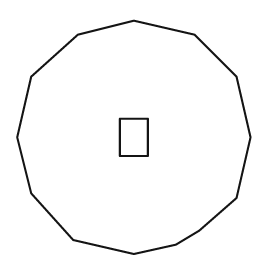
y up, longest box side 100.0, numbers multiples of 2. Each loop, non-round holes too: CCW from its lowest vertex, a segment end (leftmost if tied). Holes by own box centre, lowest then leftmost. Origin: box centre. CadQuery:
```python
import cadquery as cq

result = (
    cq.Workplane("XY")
    .moveTo(0.0, -50.0)
    .lineTo(18.0, -46.0)
    .lineTo(28.0, -40.0)
    .lineTo(44.0, -26.0)
    .lineTo(50.0, 0.0)
    .lineTo(44.0, 26.0)
    .lineTo(26.0, 44.0)
    .lineTo(0.0, 50.0)
    .lineTo(-24.0, 44.0)
    .lineTo(-44.0, 26.0)
    .lineTo(-50.0, 0.0)
    .lineTo(-44.0, -24.0)
    .lineTo(-26.0, -44.0)
    .close()
    .moveTo(-6.0, -8.0)
    .lineTo(6.0, -8.0)
    .lineTo(6.0, 8.0)
    .lineTo(-6.0, 8.0)
    .close()
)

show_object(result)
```